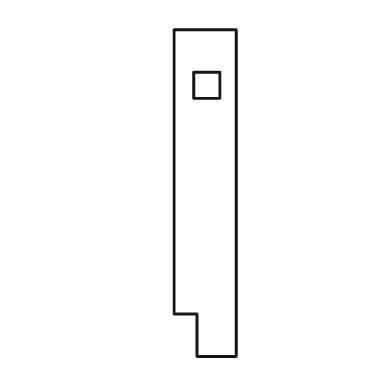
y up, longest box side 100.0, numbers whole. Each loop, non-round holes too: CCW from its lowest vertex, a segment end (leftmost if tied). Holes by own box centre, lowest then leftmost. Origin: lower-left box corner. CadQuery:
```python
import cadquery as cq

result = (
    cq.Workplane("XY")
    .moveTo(7.0, 0.0)
    .lineTo(19.0, 0.0)
    .lineTo(19.0, 100.0)
    .lineTo(0.0, 100.0)
    .lineTo(0.0, 13.0)
    .lineTo(7.0, 13.0)
    .close()
    .moveTo(6.0, 79.0)
    .lineTo(14.0, 79.0)
    .lineTo(14.0, 87.0)
    .lineTo(6.0, 87.0)
    .close()
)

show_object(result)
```